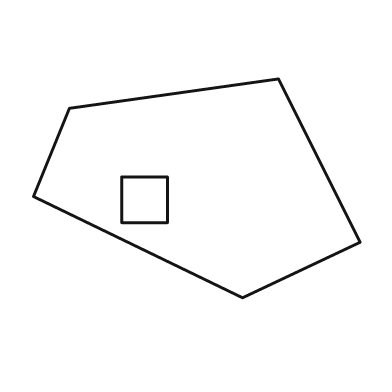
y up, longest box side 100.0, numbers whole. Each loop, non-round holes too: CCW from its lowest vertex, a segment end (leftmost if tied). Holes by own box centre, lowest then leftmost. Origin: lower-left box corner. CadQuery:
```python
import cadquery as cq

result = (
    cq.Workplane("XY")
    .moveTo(64.0, 0.0)
    .lineTo(100.0, 17.0)
    .lineTo(75.0, 67.0)
    .lineTo(11.0, 58.0)
    .lineTo(0.0, 31.0)
    .close()
    .moveTo(27.0, 23.0)
    .lineTo(41.0, 23.0)
    .lineTo(41.0, 37.0)
    .lineTo(27.0, 37.0)
    .close()
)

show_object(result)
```